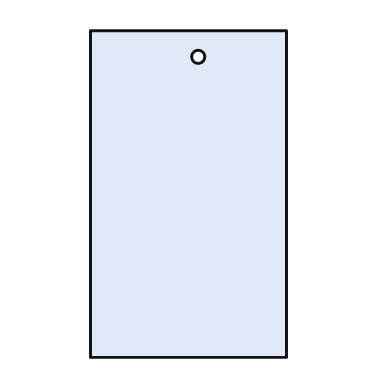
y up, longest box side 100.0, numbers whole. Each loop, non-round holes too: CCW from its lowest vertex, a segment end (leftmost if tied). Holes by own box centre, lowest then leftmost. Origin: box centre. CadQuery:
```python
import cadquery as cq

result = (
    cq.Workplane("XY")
    .moveTo(-30.0, -50.0)
    .lineTo(30.0, -50.0)
    .lineTo(30.0, 50.0)
    .lineTo(-30.0, 50.0)
    .close()
    .moveTo(3.0, 42.0)
    .circle(2.0)
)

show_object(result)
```